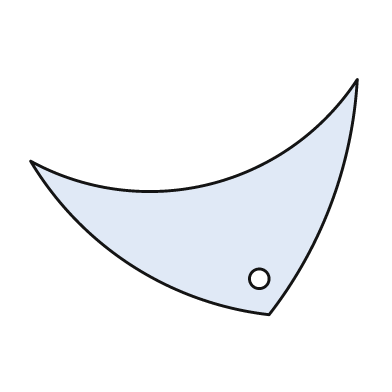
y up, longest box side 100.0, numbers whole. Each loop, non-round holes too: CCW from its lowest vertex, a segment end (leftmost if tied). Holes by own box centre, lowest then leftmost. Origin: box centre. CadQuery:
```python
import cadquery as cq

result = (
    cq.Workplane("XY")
    .moveTo(23.0, -36.0)
    .threePointArc((42.0, -2.0), (50.0, 36.0))
    .threePointArc((5.0, 4.0), (-50.0, 11.0))
    .threePointArc((-19.0, -21.0), (23.0, -36.0))
    .close()
    .moveTo(20.0, -25.0)
    .circle(3.0)
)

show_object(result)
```